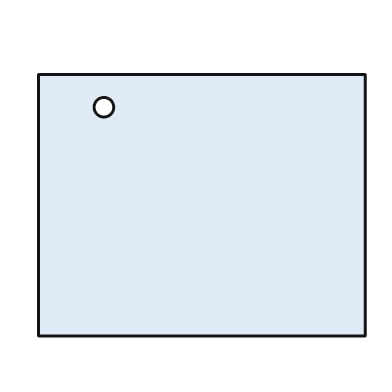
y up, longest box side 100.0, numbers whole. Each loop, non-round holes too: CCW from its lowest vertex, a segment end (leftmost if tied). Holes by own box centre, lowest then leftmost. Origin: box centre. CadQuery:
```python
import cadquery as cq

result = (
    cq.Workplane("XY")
    .moveTo(-50.0, -40.0)
    .lineTo(50.0, -40.0)
    .lineTo(50.0, 40.0)
    .lineTo(-50.0, 40.0)
    .close()
    .moveTo(-30.0, 30.0)
    .circle(3.0)
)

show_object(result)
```